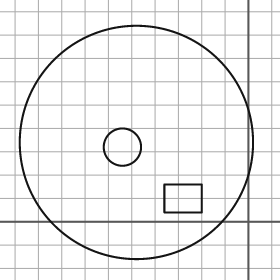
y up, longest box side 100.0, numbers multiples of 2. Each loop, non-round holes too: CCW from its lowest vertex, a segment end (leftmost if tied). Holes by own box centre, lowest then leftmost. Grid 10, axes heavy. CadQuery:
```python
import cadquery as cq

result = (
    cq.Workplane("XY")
    .moveTo(-48.0, 34.0)
    .circle(50.0)
    .moveTo(-36.0, 4.0)
    .lineTo(-20.0, 4.0)
    .lineTo(-20.0, 16.0)
    .lineTo(-36.0, 16.0)
    .close()
    .moveTo(-54.0, 32.0)
    .circle(8.0)
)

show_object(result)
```